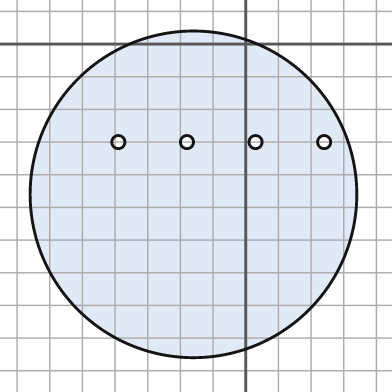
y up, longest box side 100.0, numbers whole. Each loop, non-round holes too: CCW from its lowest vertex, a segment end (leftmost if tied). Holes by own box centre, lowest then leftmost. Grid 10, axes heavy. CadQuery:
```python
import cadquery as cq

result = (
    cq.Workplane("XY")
    .moveTo(-16.0, -46.0)
    .circle(50.0)
    .moveTo(-39.0, -30.0)
    .circle(2.0)
    .moveTo(-18.0, -30.0)
    .circle(2.0)
    .moveTo(3.0, -30.0)
    .circle(2.0)
    .moveTo(24.0, -30.0)
    .circle(2.0)
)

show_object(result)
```